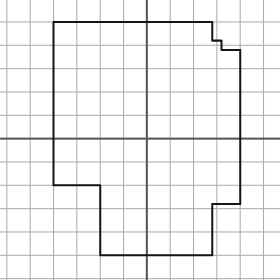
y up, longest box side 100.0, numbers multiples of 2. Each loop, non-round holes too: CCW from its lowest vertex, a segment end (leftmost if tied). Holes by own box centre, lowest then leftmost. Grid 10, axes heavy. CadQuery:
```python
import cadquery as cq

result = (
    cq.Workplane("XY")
    .moveTo(-20.0, -50.0)
    .lineTo(28.0, -50.0)
    .lineTo(28.0, -28.0)
    .lineTo(40.0, -28.0)
    .lineTo(40.0, 38.0)
    .lineTo(32.0, 38.0)
    .lineTo(32.0, 42.0)
    .lineTo(28.0, 42.0)
    .lineTo(28.0, 50.0)
    .lineTo(-40.0, 50.0)
    .lineTo(-40.0, -20.0)
    .lineTo(-20.0, -20.0)
    .close()
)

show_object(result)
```